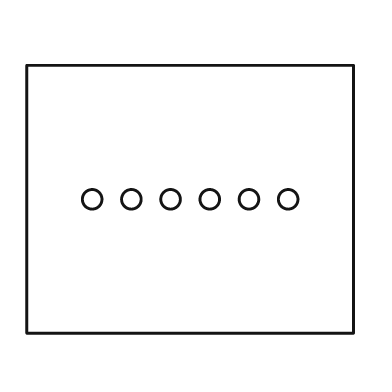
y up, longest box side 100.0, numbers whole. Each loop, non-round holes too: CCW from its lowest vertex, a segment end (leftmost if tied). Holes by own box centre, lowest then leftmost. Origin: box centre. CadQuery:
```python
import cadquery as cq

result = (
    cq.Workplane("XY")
    .moveTo(-50.0, -41.0)
    .lineTo(50.0, -41.0)
    .lineTo(50.0, 41.0)
    .lineTo(-50.0, 41.0)
    .close()
    .moveTo(-30.0, 0.0)
    .circle(3.0)
    .moveTo(-18.0, 0.0)
    .circle(3.0)
    .moveTo(-6.0, 0.0)
    .circle(3.0)
    .moveTo(6.0, 0.0)
    .circle(3.0)
    .moveTo(18.0, 0.0)
    .circle(3.0)
    .moveTo(30.0, 0.0)
    .circle(3.0)
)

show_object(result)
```